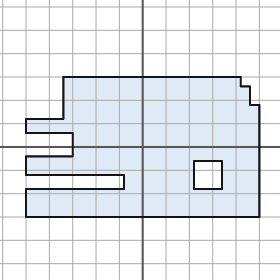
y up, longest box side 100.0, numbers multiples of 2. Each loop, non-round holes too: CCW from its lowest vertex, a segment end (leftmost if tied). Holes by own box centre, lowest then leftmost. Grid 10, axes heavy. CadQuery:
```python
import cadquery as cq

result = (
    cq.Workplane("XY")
    .moveTo(-50.0, -30.0)
    .lineTo(50.0, -30.0)
    .lineTo(50.0, 18.0)
    .lineTo(46.0, 18.0)
    .lineTo(46.0, 26.0)
    .lineTo(42.0, 26.0)
    .lineTo(42.0, 30.0)
    .lineTo(-34.0, 30.0)
    .lineTo(-34.0, 12.0)
    .lineTo(-50.0, 12.0)
    .lineTo(-50.0, 6.0)
    .lineTo(-30.0, 6.0)
    .lineTo(-30.0, -4.0)
    .lineTo(-50.0, -4.0)
    .lineTo(-50.0, -12.0)
    .lineTo(-8.0, -12.0)
    .lineTo(-8.0, -18.0)
    .lineTo(-50.0, -18.0)
    .close()
    .moveTo(22.0, -18.0)
    .lineTo(34.0, -18.0)
    .lineTo(34.0, -6.0)
    .lineTo(22.0, -6.0)
    .close()
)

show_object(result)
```